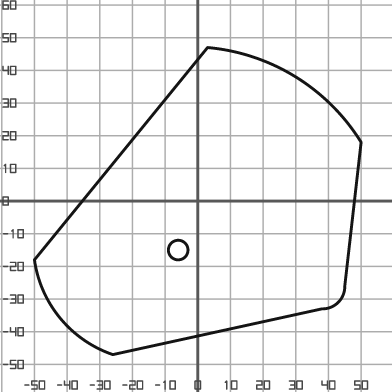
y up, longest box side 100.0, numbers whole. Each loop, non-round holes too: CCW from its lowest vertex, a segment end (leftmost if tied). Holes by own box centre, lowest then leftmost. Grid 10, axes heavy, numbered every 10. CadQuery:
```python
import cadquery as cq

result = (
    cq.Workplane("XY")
    .moveTo(-26.0, -47.0)
    .lineTo(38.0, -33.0)
    .threePointArc((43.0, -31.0), (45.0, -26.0))
    .lineTo(50.0, 18.0)
    .threePointArc((30.0, 38.0), (3.0, 47.0))
    .lineTo(-50.0, -18.0)
    .threePointArc((-42.0, -36.0), (-26.0, -47.0))
    .close()
    .moveTo(-6.0, -15.0)
    .circle(3.0)
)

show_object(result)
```